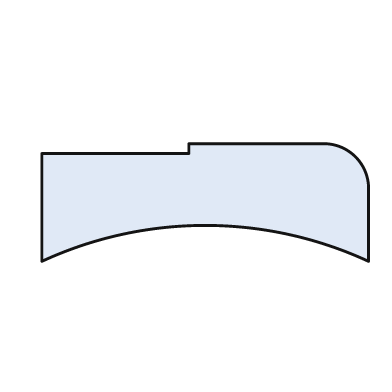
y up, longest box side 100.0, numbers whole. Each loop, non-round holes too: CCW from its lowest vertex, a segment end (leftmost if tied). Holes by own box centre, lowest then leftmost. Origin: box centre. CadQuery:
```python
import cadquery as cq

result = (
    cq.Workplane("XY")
    .moveTo(-50.0, -18.0)
    .threePointArc((0.0, -7.0), (50.0, -18.0))
    .lineTo(50.0, 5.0)
    .threePointArc((46.0, 14.0), (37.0, 18.0))
    .lineTo(-5.0, 18.0)
    .lineTo(-5.0, 15.0)
    .lineTo(-50.0, 15.0)
    .close()
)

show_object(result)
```